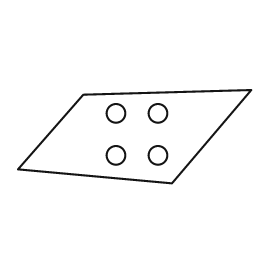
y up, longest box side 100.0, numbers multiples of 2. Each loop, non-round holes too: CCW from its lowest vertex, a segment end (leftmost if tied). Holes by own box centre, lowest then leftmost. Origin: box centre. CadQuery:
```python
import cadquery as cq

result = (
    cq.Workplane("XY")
    .moveTo(16.0, -20.0)
    .lineTo(50.0, 20.0)
    .lineTo(-22.0, 18.0)
    .lineTo(-50.0, -14.0)
    .close()
    .moveTo(-8.0, -8.0)
    .circle(4.0)
    .moveTo(10.0, -8.0)
    .circle(4.0)
    .moveTo(-8.0, 10.0)
    .circle(4.0)
    .moveTo(10.0, 10.0)
    .circle(4.0)
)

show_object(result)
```